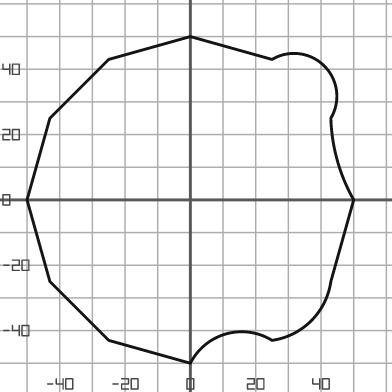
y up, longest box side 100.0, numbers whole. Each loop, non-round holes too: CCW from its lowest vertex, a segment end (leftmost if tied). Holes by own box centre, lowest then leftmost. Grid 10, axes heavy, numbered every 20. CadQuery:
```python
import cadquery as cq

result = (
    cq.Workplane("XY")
    .moveTo(0.0, -50.0)
    .threePointArc((11.0, -41.0), (25.0, -43.0))
    .threePointArc((37.0, -37.0), (43.0, -25.0))
    .lineTo(50.0, 0.0)
    .threePointArc((45.0, 12.0), (43.0, 25.0))
    .threePointArc((41.0, 41.0), (25.0, 43.0))
    .lineTo(0.0, 50.0)
    .lineTo(-25.0, 43.0)
    .lineTo(-43.0, 25.0)
    .lineTo(-50.0, 0.0)
    .lineTo(-43.0, -25.0)
    .lineTo(-25.0, -43.0)
    .close()
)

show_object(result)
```